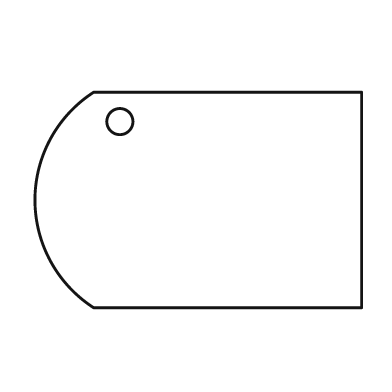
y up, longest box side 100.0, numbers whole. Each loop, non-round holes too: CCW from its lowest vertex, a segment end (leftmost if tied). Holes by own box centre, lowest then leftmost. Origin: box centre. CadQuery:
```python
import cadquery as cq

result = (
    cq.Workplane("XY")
    .moveTo(-32.0, -33.0)
    .lineTo(50.0, -33.0)
    .lineTo(50.0, 33.0)
    .lineTo(-32.0, 33.0)
    .threePointArc((-50.0, 0.0), (-32.0, -33.0))
    .close()
    .moveTo(-24.0, 24.0)
    .circle(4.0)
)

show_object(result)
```